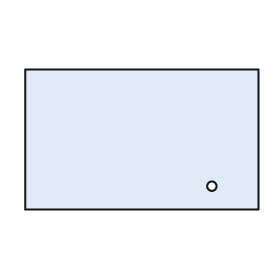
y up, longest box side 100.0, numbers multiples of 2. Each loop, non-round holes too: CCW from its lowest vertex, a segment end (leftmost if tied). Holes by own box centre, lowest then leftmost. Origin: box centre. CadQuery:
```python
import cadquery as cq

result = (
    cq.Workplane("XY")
    .moveTo(-50.0, -30.0)
    .lineTo(50.0, -30.0)
    .lineTo(50.0, 30.0)
    .lineTo(-50.0, 30.0)
    .close()
    .moveTo(30.0, -20.0)
    .circle(2.0)
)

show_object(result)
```